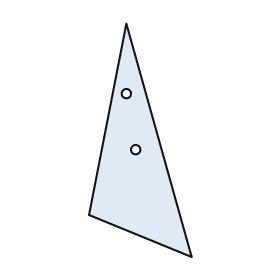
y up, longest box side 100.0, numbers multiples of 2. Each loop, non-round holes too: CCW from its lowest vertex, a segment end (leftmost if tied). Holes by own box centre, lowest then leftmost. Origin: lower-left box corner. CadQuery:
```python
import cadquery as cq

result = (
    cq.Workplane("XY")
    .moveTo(44.0, 0.0)
    .lineTo(16.0, 100.0)
    .lineTo(0.0, 18.0)
    .close()
    .moveTo(20.0, 46.0)
    .circle(2.0)
    .moveTo(16.0, 70.0)
    .circle(2.0)
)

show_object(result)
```